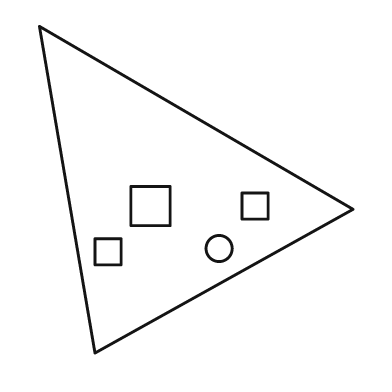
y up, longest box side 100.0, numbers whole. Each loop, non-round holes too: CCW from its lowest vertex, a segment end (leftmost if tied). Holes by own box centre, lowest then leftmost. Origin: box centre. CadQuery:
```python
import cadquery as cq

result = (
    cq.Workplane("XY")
    .moveTo(-31.0, -50.0)
    .lineTo(48.0, -6.0)
    .lineTo(-48.0, 50.0)
    .close()
    .moveTo(-31.0, -23.0)
    .lineTo(-23.0, -23.0)
    .lineTo(-23.0, -15.0)
    .lineTo(-31.0, -15.0)
    .close()
    .moveTo(7.0, -18.0)
    .circle(4.0)
    .moveTo(-20.0, -11.0)
    .lineTo(-8.0, -11.0)
    .lineTo(-8.0, 1.0)
    .lineTo(-20.0, 1.0)
    .close()
    .moveTo(14.0, -9.0)
    .lineTo(22.0, -9.0)
    .lineTo(22.0, -1.0)
    .lineTo(14.0, -1.0)
    .close()
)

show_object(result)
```